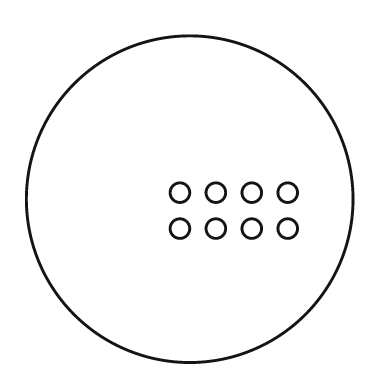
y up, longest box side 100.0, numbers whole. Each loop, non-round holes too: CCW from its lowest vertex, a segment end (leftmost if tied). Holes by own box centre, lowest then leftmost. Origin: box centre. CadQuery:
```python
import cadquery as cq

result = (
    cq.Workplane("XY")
    .moveTo(0.0, 0.0)
    .circle(50.0)
    .moveTo(-3.0, -9.0)
    .circle(3.0)
    .moveTo(8.0, -9.0)
    .circle(3.0)
    .moveTo(19.0, -9.0)
    .circle(3.0)
    .moveTo(30.0, -9.0)
    .circle(3.0)
    .moveTo(-3.0, 2.0)
    .circle(3.0)
    .moveTo(8.0, 2.0)
    .circle(3.0)
    .moveTo(19.0, 2.0)
    .circle(3.0)
    .moveTo(30.0, 2.0)
    .circle(3.0)
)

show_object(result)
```